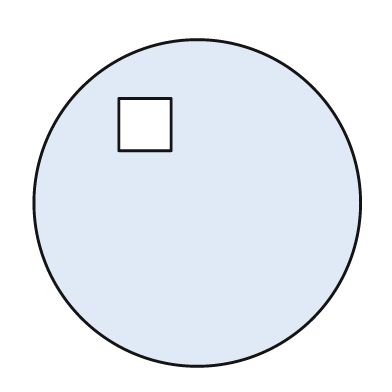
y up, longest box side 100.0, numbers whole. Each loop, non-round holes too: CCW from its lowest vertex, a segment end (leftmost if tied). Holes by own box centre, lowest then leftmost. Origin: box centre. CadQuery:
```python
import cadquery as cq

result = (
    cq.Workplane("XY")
    .moveTo(0.0, 0.0)
    .circle(50.0)
    .moveTo(-24.0, 16.0)
    .lineTo(-8.0, 16.0)
    .lineTo(-8.0, 32.0)
    .lineTo(-24.0, 32.0)
    .close()
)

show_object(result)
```